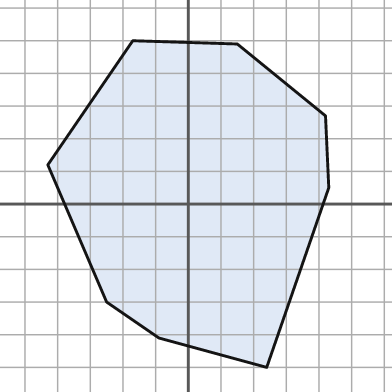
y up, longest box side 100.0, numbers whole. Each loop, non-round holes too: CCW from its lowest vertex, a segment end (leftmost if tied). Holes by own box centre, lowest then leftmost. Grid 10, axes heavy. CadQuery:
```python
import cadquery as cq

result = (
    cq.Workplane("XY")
    .moveTo(24.0, -50.0)
    .lineTo(43.0, 5.0)
    .lineTo(42.0, 27.0)
    .lineTo(15.0, 49.0)
    .lineTo(-17.0, 50.0)
    .lineTo(-43.0, 12.0)
    .lineTo(-25.0, -30.0)
    .lineTo(-9.0, -41.0)
    .close()
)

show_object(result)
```